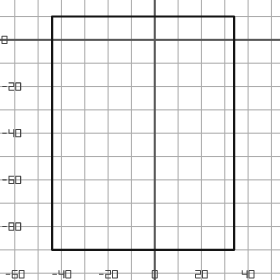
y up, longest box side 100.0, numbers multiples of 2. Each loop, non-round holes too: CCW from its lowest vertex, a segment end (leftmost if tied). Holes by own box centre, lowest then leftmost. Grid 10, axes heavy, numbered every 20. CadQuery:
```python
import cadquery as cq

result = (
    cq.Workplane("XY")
    .moveTo(-44.0, -90.0)
    .lineTo(34.0, -90.0)
    .lineTo(34.0, 10.0)
    .lineTo(-44.0, 10.0)
    .close()
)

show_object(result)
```